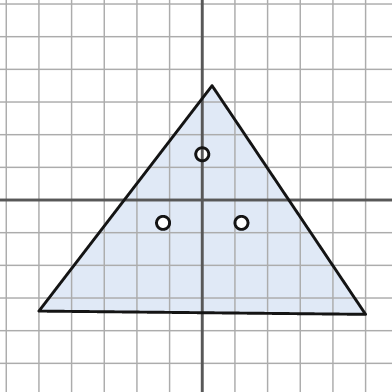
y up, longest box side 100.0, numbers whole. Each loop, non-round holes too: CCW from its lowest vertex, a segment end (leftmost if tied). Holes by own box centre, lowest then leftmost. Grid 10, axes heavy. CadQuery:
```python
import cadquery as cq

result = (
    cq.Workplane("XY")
    .moveTo(50.0, -35.0)
    .lineTo(3.0, 35.0)
    .lineTo(-50.0, -34.0)
    .close()
    .moveTo(-12.0, -7.0)
    .circle(2.0)
    .moveTo(12.0, -7.0)
    .circle(2.0)
    .moveTo(0.0, 14.0)
    .circle(2.0)
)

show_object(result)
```